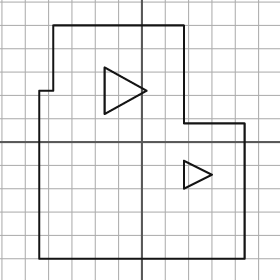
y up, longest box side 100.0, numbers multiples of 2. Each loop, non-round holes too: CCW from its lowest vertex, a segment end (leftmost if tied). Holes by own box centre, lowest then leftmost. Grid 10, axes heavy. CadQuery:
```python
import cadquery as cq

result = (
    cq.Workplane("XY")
    .moveTo(-44.0, -50.0)
    .lineTo(44.0, -50.0)
    .lineTo(44.0, 8.0)
    .lineTo(18.0, 8.0)
    .lineTo(18.0, 50.0)
    .lineTo(-38.0, 50.0)
    .lineTo(-38.0, 22.0)
    .lineTo(-44.0, 22.0)
    .close()
    .moveTo(18.0, -20.0)
    .lineTo(30.0, -14.0)
    .lineTo(18.0, -8.0)
    .close()
    .moveTo(-16.0, 12.0)
    .lineTo(2.0, 22.0)
    .lineTo(-16.0, 32.0)
    .close()
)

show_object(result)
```